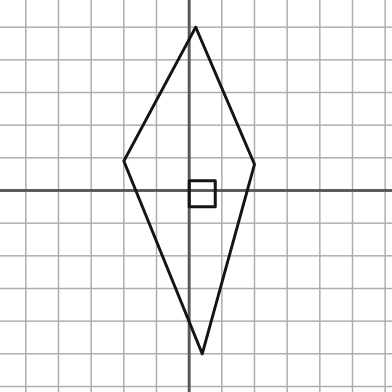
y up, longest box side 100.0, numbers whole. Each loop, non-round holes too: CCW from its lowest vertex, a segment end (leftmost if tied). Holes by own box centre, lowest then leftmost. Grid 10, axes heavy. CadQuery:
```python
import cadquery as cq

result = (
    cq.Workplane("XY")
    .moveTo(4.0, -50.0)
    .lineTo(20.0, 8.0)
    .lineTo(2.0, 50.0)
    .lineTo(-20.0, 9.0)
    .close()
    .moveTo(0.0, -5.0)
    .lineTo(8.0, -5.0)
    .lineTo(8.0, 3.0)
    .lineTo(0.0, 3.0)
    .close()
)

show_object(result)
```